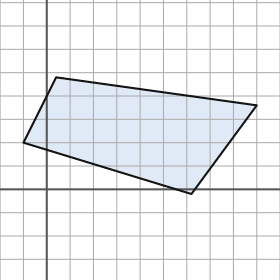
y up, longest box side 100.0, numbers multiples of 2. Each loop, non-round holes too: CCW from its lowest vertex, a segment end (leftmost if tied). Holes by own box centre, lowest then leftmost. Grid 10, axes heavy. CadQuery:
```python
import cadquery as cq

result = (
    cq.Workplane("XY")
    .moveTo(62.0, -2.0)
    .lineTo(90.0, 36.0)
    .lineTo(4.0, 48.0)
    .lineTo(-10.0, 20.0)
    .close()
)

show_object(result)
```